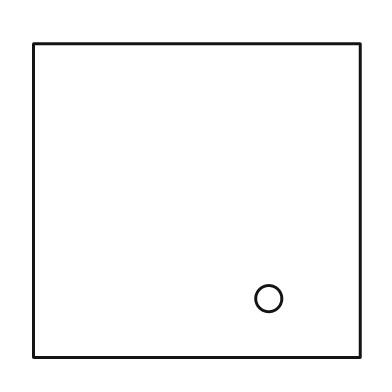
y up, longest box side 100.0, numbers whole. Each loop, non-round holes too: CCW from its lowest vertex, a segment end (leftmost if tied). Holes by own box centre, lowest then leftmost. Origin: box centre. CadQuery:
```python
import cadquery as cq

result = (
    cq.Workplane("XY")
    .moveTo(-50.0, -48.0)
    .lineTo(50.0, -48.0)
    .lineTo(50.0, 48.0)
    .lineTo(-50.0, 48.0)
    .close()
    .moveTo(22.0, -30.0)
    .circle(4.0)
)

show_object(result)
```